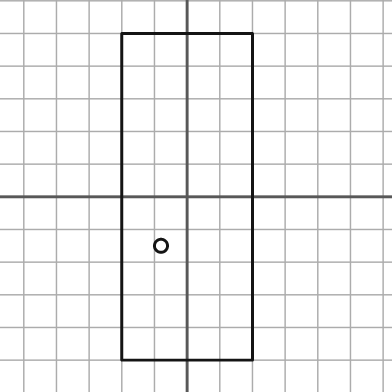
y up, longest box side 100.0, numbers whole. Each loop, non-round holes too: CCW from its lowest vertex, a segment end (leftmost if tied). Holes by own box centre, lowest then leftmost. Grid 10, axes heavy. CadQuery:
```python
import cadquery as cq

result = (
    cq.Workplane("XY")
    .moveTo(-20.0, -50.0)
    .lineTo(20.0, -50.0)
    .lineTo(20.0, 50.0)
    .lineTo(-20.0, 50.0)
    .close()
    .moveTo(-8.0, -15.0)
    .circle(2.0)
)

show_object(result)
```